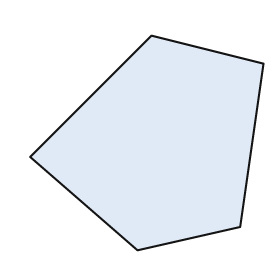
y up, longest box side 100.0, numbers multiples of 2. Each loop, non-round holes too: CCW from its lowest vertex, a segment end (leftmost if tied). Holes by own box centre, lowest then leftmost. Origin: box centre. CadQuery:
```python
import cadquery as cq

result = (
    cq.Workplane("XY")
    .moveTo(-4.0, -46.0)
    .lineTo(40.0, -36.0)
    .lineTo(50.0, 34.0)
    .lineTo(2.0, 46.0)
    .lineTo(-50.0, -6.0)
    .close()
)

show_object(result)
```